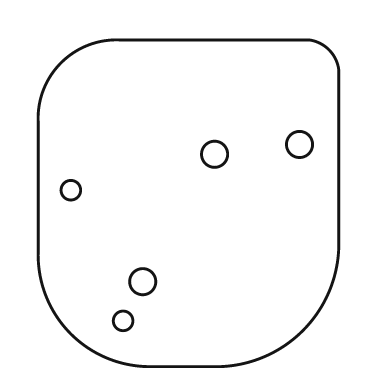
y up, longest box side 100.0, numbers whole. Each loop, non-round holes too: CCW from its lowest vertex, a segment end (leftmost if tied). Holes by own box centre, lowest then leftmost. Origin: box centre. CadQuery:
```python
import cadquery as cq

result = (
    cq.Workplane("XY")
    .moveTo(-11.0, -50.0)
    .lineTo(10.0, -50.0)
    .threePointArc((35.0, -39.0), (46.0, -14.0))
    .lineTo(46.0, 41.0)
    .threePointArc((43.0, 47.0), (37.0, 50.0))
    .lineTo(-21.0, 50.0)
    .threePointArc((-39.0, 43.0), (-46.0, 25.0))
    .lineTo(-46.0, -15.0)
    .threePointArc((-36.0, -40.0), (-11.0, -50.0))
    .close()
    .moveTo(-20.0, -36.0)
    .circle(3.0)
    .moveTo(-14.0, -24.0)
    .circle(4.0)
    .moveTo(-36.0, 4.0)
    .circle(3.0)
    .moveTo(8.0, 15.0)
    .circle(4.0)
    .moveTo(34.0, 18.0)
    .circle(4.0)
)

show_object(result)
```